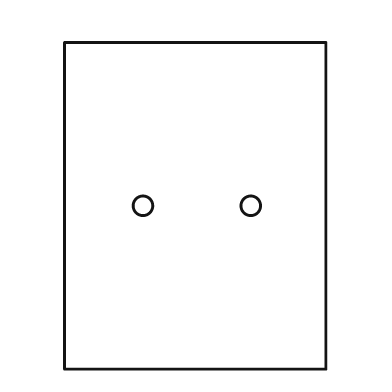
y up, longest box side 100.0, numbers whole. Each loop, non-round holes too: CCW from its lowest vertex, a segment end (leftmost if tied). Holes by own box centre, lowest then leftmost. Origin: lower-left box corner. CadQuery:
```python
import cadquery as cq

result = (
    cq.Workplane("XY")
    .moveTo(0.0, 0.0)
    .lineTo(80.0, 0.0)
    .lineTo(80.0, 100.0)
    .lineTo(0.0, 100.0)
    .close()
    .moveTo(24.0, 50.0)
    .circle(3.0)
    .moveTo(57.0, 50.0)
    .circle(3.0)
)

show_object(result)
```